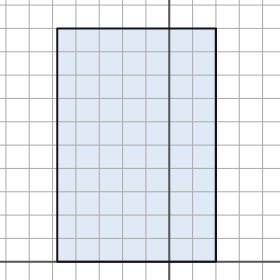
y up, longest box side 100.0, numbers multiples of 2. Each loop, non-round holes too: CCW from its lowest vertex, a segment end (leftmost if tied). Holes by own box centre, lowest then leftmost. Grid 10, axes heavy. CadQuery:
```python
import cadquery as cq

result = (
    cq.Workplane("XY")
    .moveTo(-48.0, 0.0)
    .lineTo(20.0, 0.0)
    .lineTo(20.0, 100.0)
    .lineTo(-48.0, 100.0)
    .close()
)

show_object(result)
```